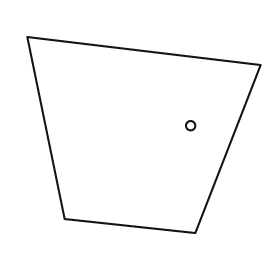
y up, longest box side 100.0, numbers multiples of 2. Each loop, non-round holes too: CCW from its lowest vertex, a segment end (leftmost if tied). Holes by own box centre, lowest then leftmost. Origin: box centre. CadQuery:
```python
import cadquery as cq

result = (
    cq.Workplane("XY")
    .moveTo(22.0, -42.0)
    .lineTo(50.0, 30.0)
    .lineTo(-50.0, 42.0)
    .lineTo(-34.0, -36.0)
    .close()
    .moveTo(20.0, 4.0)
    .circle(2.0)
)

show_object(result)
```